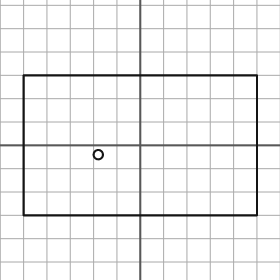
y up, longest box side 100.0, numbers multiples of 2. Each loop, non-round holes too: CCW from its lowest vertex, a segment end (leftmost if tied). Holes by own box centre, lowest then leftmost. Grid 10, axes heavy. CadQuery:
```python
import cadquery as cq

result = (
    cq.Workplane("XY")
    .moveTo(-50.0, -30.0)
    .lineTo(50.0, -30.0)
    .lineTo(50.0, 30.0)
    .lineTo(-50.0, 30.0)
    .close()
    .moveTo(-18.0, -4.0)
    .circle(2.0)
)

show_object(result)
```